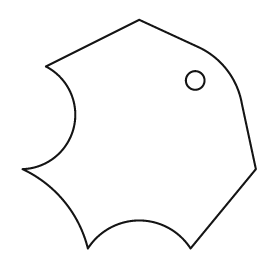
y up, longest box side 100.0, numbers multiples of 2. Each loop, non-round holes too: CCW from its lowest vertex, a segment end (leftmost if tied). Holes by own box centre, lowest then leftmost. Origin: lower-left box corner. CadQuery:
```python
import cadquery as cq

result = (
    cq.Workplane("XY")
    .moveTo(28.0, 0.0)
    .threePointArc((50.0, 12.0), (72.0, 0.0))
    .lineTo(100.0, 34.0)
    .lineTo(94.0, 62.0)
    .threePointArc((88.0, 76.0), (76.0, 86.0))
    .lineTo(50.0, 98.0)
    .lineTo(10.0, 78.0)
    .threePointArc((22.0, 52.0), (0.0, 34.0))
    .threePointArc((18.0, 20.0), (28.0, 0.0))
    .close()
    .moveTo(74.0, 72.0)
    .circle(4.0)
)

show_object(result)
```